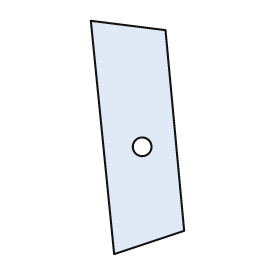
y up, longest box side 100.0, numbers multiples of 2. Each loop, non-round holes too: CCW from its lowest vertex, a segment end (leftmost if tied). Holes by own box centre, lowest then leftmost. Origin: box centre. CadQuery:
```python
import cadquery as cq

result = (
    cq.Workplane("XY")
    .moveTo(-10.0, -50.0)
    .lineTo(20.0, -40.0)
    .lineTo(12.0, 46.0)
    .lineTo(-20.0, 50.0)
    .close()
    .moveTo(2.0, -4.0)
    .circle(4.0)
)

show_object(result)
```